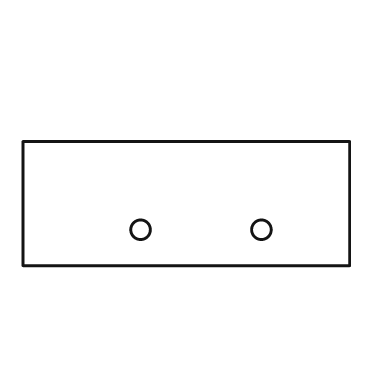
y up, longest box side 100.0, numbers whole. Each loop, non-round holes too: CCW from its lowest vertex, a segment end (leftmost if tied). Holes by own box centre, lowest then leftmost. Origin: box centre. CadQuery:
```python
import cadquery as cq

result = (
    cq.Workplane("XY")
    .moveTo(-50.0, -19.0)
    .lineTo(50.0, -19.0)
    .lineTo(50.0, 19.0)
    .lineTo(-50.0, 19.0)
    .close()
    .moveTo(-14.0, -8.0)
    .circle(3.0)
    .moveTo(23.0, -8.0)
    .circle(3.0)
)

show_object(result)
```